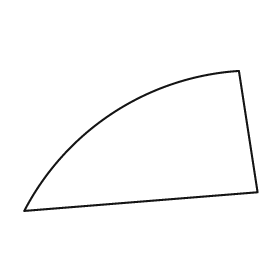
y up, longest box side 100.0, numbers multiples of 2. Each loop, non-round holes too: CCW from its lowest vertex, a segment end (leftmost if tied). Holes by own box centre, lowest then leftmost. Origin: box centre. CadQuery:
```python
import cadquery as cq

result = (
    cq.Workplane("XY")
    .moveTo(-50.0, -30.0)
    .lineTo(50.0, -22.0)
    .lineTo(42.0, 30.0)
    .threePointArc((-12.0, 12.0), (-50.0, -30.0))
    .close()
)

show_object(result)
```